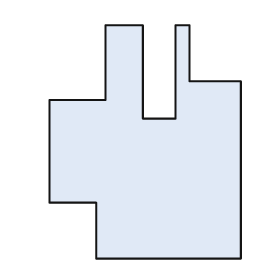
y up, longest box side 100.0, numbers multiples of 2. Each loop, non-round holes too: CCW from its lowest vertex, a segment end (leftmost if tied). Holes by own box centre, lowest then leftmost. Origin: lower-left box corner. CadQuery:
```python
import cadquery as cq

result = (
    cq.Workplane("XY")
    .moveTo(20.0, 0.0)
    .lineTo(82.0, 0.0)
    .lineTo(82.0, 76.0)
    .lineTo(60.0, 76.0)
    .lineTo(60.0, 100.0)
    .lineTo(54.0, 100.0)
    .lineTo(54.0, 60.0)
    .lineTo(40.0, 60.0)
    .lineTo(40.0, 100.0)
    .lineTo(24.0, 100.0)
    .lineTo(24.0, 68.0)
    .lineTo(0.0, 68.0)
    .lineTo(0.0, 24.0)
    .lineTo(20.0, 24.0)
    .close()
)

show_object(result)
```